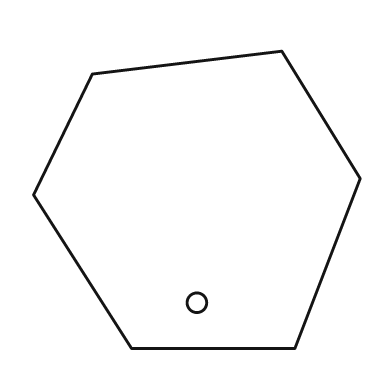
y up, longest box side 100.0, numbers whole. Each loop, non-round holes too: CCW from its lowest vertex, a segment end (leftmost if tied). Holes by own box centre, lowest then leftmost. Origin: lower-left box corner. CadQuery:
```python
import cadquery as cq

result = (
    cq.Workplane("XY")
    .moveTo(30.0, 0.0)
    .lineTo(80.0, 0.0)
    .lineTo(100.0, 52.0)
    .lineTo(76.0, 91.0)
    .lineTo(18.0, 84.0)
    .lineTo(0.0, 47.0)
    .close()
    .moveTo(50.0, 14.0)
    .circle(3.0)
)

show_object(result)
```